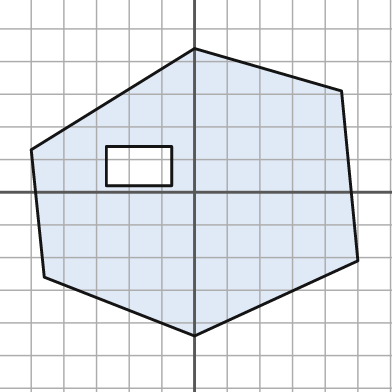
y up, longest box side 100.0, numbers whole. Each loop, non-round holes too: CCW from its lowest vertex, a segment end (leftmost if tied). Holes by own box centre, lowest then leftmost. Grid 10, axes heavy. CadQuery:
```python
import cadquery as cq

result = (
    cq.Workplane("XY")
    .moveTo(0.0, -44.0)
    .lineTo(50.0, -21.0)
    .lineTo(45.0, 31.0)
    .lineTo(0.0, 44.0)
    .lineTo(-50.0, 13.0)
    .lineTo(-46.0, -26.0)
    .close()
    .moveTo(-27.0, 2.0)
    .lineTo(-7.0, 2.0)
    .lineTo(-7.0, 14.0)
    .lineTo(-27.0, 14.0)
    .close()
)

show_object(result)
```